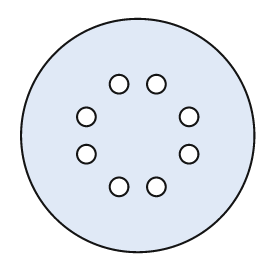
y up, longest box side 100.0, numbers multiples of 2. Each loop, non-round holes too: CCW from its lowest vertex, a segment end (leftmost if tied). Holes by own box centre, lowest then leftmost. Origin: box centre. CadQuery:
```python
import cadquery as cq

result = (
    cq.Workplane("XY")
    .moveTo(0.0, 0.0)
    .circle(50.0)
    .moveTo(-8.0, -22.0)
    .circle(4.0)
    .moveTo(8.0, -22.0)
    .circle(4.0)
    .moveTo(-22.0, -8.0)
    .circle(4.0)
    .moveTo(22.0, -8.0)
    .circle(4.0)
    .moveTo(-22.0, 8.0)
    .circle(4.0)
    .moveTo(22.0, 8.0)
    .circle(4.0)
    .moveTo(-8.0, 22.0)
    .circle(4.0)
    .moveTo(8.0, 22.0)
    .circle(4.0)
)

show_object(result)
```